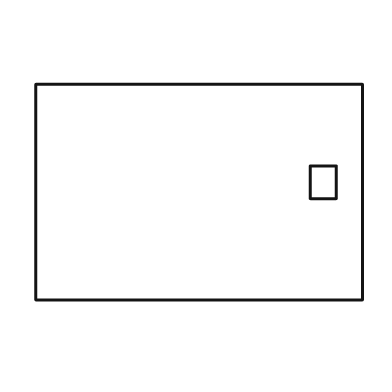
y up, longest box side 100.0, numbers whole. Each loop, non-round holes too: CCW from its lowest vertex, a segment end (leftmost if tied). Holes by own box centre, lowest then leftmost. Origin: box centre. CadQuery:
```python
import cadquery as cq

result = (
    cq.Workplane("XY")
    .moveTo(-50.0, -33.0)
    .lineTo(50.0, -33.0)
    .lineTo(50.0, 33.0)
    .lineTo(-50.0, 33.0)
    .close()
    .moveTo(34.0, -2.0)
    .lineTo(42.0, -2.0)
    .lineTo(42.0, 8.0)
    .lineTo(34.0, 8.0)
    .close()
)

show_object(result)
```